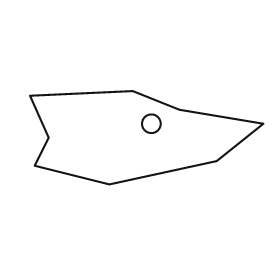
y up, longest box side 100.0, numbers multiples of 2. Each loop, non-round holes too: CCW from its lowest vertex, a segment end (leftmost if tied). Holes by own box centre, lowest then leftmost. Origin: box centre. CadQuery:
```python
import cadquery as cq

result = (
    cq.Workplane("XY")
    .moveTo(-16.0, -20.0)
    .lineTo(30.0, -10.0)
    .lineTo(50.0, 6.0)
    .lineTo(14.0, 12.0)
    .lineTo(-6.0, 20.0)
    .lineTo(-50.0, 18.0)
    .lineTo(-42.0, 0.0)
    .lineTo(-48.0, -12.0)
    .close()
    .moveTo(2.0, 6.0)
    .circle(4.0)
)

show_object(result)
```